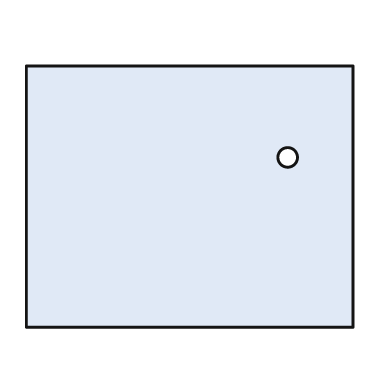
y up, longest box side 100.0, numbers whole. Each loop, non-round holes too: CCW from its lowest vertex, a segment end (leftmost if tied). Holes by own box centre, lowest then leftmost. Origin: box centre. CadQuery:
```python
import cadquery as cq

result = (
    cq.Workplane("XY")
    .moveTo(-50.0, -40.0)
    .lineTo(50.0, -40.0)
    .lineTo(50.0, 40.0)
    .lineTo(-50.0, 40.0)
    .close()
    .moveTo(30.0, 12.0)
    .circle(3.0)
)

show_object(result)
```